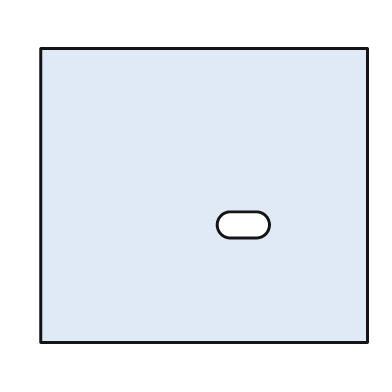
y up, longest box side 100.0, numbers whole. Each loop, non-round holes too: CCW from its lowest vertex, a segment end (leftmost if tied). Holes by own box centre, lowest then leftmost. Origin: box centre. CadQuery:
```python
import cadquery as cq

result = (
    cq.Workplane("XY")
    .moveTo(-50.0, -45.0)
    .lineTo(50.0, -45.0)
    .lineTo(50.0, 45.0)
    .lineTo(-50.0, 45.0)
    .close()
    .moveTo(8.0, -13.0)
    .lineTo(16.0, -13.0)
    .threePointArc((20.0, -9.0), (16.0, -5.0))
    .lineTo(8.0, -5.0)
    .threePointArc((4.0, -9.0), (8.0, -13.0))
    .close()
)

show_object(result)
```